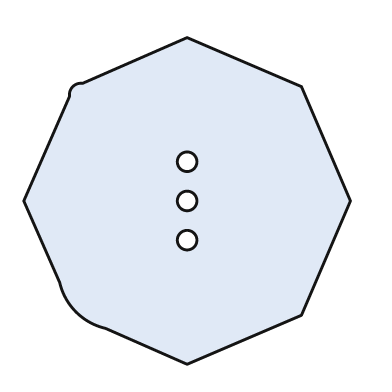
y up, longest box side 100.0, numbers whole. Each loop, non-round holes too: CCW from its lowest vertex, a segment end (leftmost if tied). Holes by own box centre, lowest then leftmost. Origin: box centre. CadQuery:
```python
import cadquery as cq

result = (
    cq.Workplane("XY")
    .moveTo(0.0, -50.0)
    .lineTo(35.0, -35.0)
    .lineTo(50.0, 0.0)
    .lineTo(35.0, 35.0)
    .lineTo(0.0, 50.0)
    .lineTo(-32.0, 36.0)
    .threePointArc((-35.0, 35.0), (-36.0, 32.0))
    .lineTo(-50.0, 0.0)
    .lineTo(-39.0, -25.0)
    .threePointArc((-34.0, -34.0), (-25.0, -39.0))
    .close()
    .moveTo(0.0, -12.0)
    .circle(3.0)
    .moveTo(0.0, 0.0)
    .circle(3.0)
    .moveTo(0.0, 12.0)
    .circle(3.0)
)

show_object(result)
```